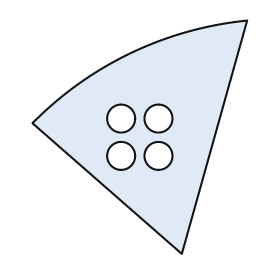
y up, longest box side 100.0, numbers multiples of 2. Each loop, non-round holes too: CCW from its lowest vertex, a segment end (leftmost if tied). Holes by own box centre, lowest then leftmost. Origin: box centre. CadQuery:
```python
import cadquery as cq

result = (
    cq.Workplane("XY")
    .moveTo(18.0, -50.0)
    .lineTo(46.0, 50.0)
    .threePointArc((-4.0, 36.0), (-46.0, 6.0))
    .close()
    .moveTo(-8.0, -8.0)
    .circle(6.0)
    .moveTo(8.0, -8.0)
    .circle(6.0)
    .moveTo(-8.0, 8.0)
    .circle(6.0)
    .moveTo(8.0, 8.0)
    .circle(6.0)
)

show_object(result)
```